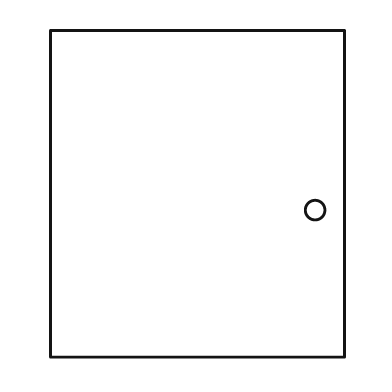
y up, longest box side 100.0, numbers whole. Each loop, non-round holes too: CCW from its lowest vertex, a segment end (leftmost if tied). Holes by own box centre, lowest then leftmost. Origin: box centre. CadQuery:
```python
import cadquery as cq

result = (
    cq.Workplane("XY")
    .moveTo(-45.0, -50.0)
    .lineTo(45.0, -50.0)
    .lineTo(45.0, 50.0)
    .lineTo(-45.0, 50.0)
    .close()
    .moveTo(36.0, -5.0)
    .circle(3.0)
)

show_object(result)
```